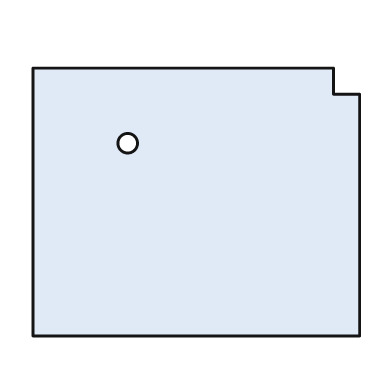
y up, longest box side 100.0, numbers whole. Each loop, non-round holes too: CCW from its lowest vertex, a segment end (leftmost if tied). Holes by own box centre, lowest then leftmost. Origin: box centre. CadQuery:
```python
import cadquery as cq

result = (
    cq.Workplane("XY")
    .moveTo(-50.0, -41.0)
    .lineTo(50.0, -41.0)
    .lineTo(50.0, 33.0)
    .lineTo(42.0, 33.0)
    .lineTo(42.0, 41.0)
    .lineTo(-50.0, 41.0)
    .close()
    .moveTo(-21.0, 18.0)
    .circle(3.0)
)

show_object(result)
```